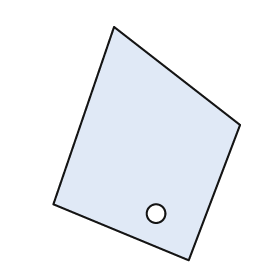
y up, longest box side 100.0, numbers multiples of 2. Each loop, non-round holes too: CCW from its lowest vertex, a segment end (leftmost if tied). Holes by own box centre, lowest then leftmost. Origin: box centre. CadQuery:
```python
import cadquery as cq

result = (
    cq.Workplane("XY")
    .moveTo(18.0, -50.0)
    .lineTo(40.0, 8.0)
    .lineTo(-14.0, 50.0)
    .lineTo(-40.0, -26.0)
    .close()
    .moveTo(4.0, -30.0)
    .circle(4.0)
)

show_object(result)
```